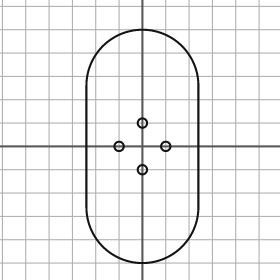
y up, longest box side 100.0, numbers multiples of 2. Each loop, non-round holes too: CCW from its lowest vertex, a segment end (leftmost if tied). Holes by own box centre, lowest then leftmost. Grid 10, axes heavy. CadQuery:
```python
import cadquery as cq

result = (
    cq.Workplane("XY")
    .moveTo(-24.0, -26.0)
    .threePointArc((0.0, -50.0), (24.0, -26.0))
    .lineTo(24.0, 26.0)
    .threePointArc((0.0, 50.0), (-24.0, 26.0))
    .close()
    .moveTo(0.0, -10.0)
    .circle(2.0)
    .moveTo(-10.0, 0.0)
    .circle(2.0)
    .moveTo(10.0, 0.0)
    .circle(2.0)
    .moveTo(0.0, 10.0)
    .circle(2.0)
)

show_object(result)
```